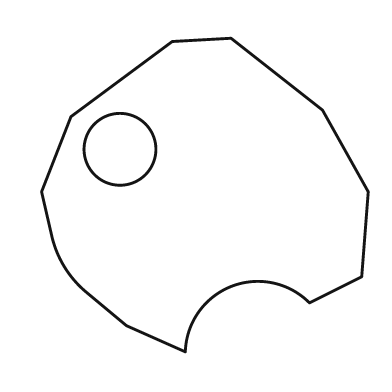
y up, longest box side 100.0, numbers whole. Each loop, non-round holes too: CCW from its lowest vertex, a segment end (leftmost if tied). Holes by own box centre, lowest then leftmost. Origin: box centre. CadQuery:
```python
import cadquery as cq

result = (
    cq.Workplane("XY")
    .moveTo(-6.0, -48.0)
    .threePointArc((8.0, -28.0), (32.0, -33.0))
    .lineTo(48.0, -25.0)
    .lineTo(50.0, 1.0)
    .lineTo(36.0, 26.0)
    .lineTo(8.0, 48.0)
    .lineTo(-10.0, 47.0)
    .lineTo(-41.0, 24.0)
    .lineTo(-50.0, 1.0)
    .lineTo(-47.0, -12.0)
    .threePointArc((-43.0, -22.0), (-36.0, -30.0))
    .lineTo(-24.0, -40.0)
    .close()
    .moveTo(-26.0, 14.0)
    .circle(11.0)
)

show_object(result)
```